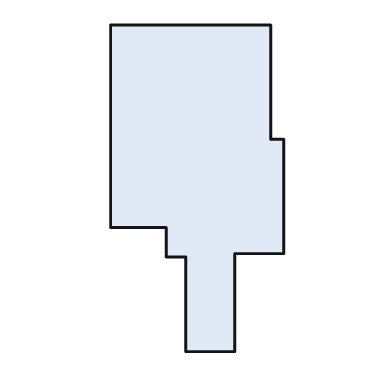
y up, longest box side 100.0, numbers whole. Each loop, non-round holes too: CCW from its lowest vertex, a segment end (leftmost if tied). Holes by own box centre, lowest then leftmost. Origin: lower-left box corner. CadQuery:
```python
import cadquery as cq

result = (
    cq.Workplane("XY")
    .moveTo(23.0, 0.0)
    .lineTo(38.0, 0.0)
    .lineTo(38.0, 30.0)
    .lineTo(53.0, 30.0)
    .lineTo(53.0, 65.0)
    .lineTo(49.0, 65.0)
    .lineTo(49.0, 100.0)
    .lineTo(0.0, 100.0)
    .lineTo(0.0, 38.0)
    .lineTo(17.0, 38.0)
    .lineTo(17.0, 29.0)
    .lineTo(23.0, 29.0)
    .close()
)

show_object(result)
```